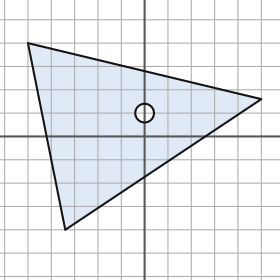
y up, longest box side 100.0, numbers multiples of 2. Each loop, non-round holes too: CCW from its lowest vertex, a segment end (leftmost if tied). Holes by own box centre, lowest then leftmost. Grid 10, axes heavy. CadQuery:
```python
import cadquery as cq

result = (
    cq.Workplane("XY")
    .moveTo(-34.0, -40.0)
    .lineTo(50.0, 16.0)
    .lineTo(-50.0, 40.0)
    .close()
    .moveTo(0.0, 10.0)
    .circle(4.0)
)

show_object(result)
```